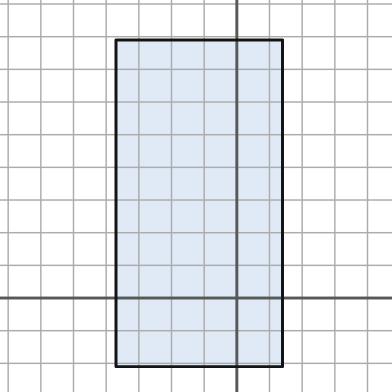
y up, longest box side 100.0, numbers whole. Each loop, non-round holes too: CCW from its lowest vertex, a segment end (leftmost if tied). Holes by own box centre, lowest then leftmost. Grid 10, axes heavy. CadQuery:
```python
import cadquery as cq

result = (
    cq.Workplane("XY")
    .moveTo(-37.0, -21.0)
    .lineTo(14.0, -21.0)
    .lineTo(14.0, 79.0)
    .lineTo(-37.0, 79.0)
    .close()
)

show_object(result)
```